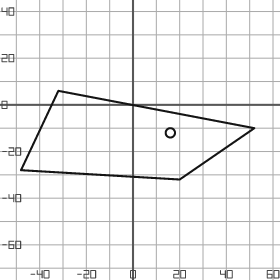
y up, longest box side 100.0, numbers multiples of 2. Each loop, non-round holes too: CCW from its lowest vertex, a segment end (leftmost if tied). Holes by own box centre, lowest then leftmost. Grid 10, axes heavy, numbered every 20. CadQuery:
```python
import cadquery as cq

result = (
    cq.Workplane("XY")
    .moveTo(20.0, -32.0)
    .lineTo(52.0, -10.0)
    .lineTo(-32.0, 6.0)
    .lineTo(-48.0, -28.0)
    .close()
    .moveTo(16.0, -12.0)
    .circle(2.0)
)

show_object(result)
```